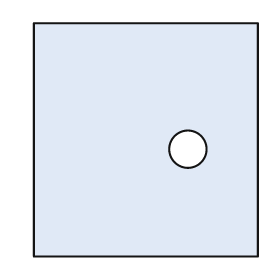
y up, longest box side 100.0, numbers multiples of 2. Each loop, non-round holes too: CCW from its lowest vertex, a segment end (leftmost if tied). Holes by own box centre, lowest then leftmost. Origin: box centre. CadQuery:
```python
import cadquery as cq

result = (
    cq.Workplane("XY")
    .moveTo(-48.0, -50.0)
    .lineTo(48.0, -50.0)
    .lineTo(48.0, 50.0)
    .lineTo(-48.0, 50.0)
    .close()
    .moveTo(18.0, -4.0)
    .circle(8.0)
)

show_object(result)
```